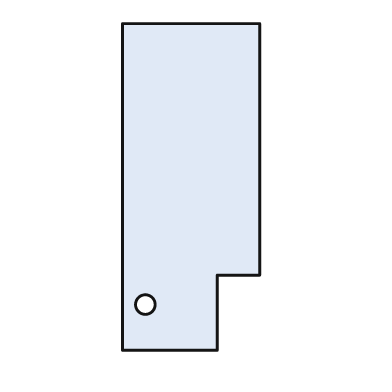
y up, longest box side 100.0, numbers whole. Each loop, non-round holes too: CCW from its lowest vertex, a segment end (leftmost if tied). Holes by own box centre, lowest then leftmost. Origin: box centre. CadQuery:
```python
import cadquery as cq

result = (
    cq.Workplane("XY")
    .moveTo(-21.0, -50.0)
    .lineTo(8.0, -50.0)
    .lineTo(8.0, -27.0)
    .lineTo(21.0, -27.0)
    .lineTo(21.0, 50.0)
    .lineTo(-21.0, 50.0)
    .close()
    .moveTo(-14.0, -36.0)
    .circle(3.0)
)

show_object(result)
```